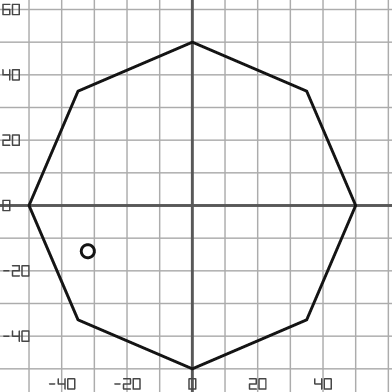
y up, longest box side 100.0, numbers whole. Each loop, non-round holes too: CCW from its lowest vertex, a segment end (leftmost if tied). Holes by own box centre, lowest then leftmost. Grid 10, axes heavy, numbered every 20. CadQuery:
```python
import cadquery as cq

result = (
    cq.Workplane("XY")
    .moveTo(0.0, -50.0)
    .lineTo(35.0, -35.0)
    .lineTo(50.0, 0.0)
    .lineTo(35.0, 35.0)
    .lineTo(0.0, 50.0)
    .lineTo(-35.0, 35.0)
    .lineTo(-50.0, 0.0)
    .lineTo(-35.0, -35.0)
    .close()
    .moveTo(-32.0, -14.0)
    .circle(2.0)
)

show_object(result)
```